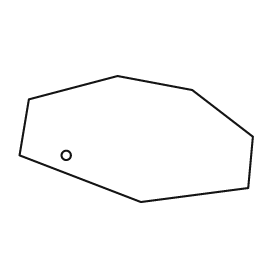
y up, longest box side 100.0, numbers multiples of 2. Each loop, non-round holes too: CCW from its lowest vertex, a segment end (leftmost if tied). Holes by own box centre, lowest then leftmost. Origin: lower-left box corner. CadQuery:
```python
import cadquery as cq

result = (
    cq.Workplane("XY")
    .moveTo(52.0, 0.0)
    .lineTo(98.0, 6.0)
    .lineTo(100.0, 28.0)
    .lineTo(74.0, 48.0)
    .lineTo(42.0, 54.0)
    .lineTo(4.0, 44.0)
    .lineTo(0.0, 20.0)
    .close()
    .moveTo(20.0, 20.0)
    .circle(2.0)
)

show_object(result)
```